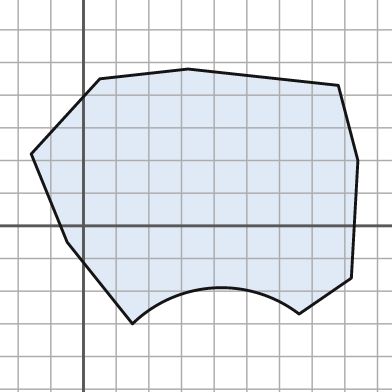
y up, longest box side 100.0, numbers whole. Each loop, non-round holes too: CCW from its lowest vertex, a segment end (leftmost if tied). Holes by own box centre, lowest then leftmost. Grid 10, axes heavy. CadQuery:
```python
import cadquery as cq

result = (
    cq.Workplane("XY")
    .moveTo(15.0, -30.0)
    .threePointArc((40.0, -19.0), (66.0, -27.0))
    .lineTo(82.0, -16.0)
    .lineTo(84.0, 20.0)
    .lineTo(78.0, 43.0)
    .lineTo(32.0, 48.0)
    .lineTo(5.0, 45.0)
    .lineTo(-16.0, 22.0)
    .lineTo(-5.0, -5.0)
    .close()
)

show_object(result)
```